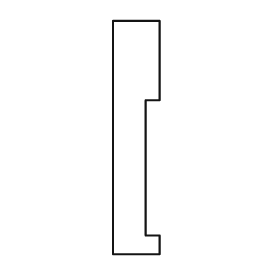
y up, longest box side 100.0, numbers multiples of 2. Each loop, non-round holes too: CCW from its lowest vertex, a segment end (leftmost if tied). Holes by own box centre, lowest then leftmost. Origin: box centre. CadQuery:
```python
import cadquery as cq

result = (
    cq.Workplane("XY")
    .moveTo(-10.0, -50.0)
    .lineTo(10.0, -50.0)
    .lineTo(10.0, -42.0)
    .lineTo(4.0, -42.0)
    .lineTo(4.0, 16.0)
    .lineTo(10.0, 16.0)
    .lineTo(10.0, 50.0)
    .lineTo(-10.0, 50.0)
    .close()
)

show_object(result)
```